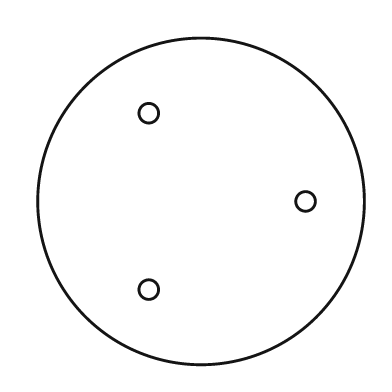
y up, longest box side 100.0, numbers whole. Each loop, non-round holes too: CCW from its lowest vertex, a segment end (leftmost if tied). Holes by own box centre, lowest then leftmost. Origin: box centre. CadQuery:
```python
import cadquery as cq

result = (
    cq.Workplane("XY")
    .moveTo(0.0, 0.0)
    .circle(50.0)
    .moveTo(-16.0, -27.0)
    .circle(3.0)
    .moveTo(32.0, 0.0)
    .circle(3.0)
    .moveTo(-16.0, 27.0)
    .circle(3.0)
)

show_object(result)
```